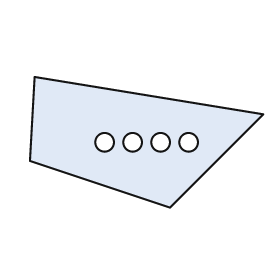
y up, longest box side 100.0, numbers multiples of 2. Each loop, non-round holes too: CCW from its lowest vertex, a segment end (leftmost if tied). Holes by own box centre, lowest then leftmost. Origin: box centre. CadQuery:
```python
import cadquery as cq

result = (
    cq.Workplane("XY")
    .moveTo(10.0, -28.0)
    .lineTo(50.0, 12.0)
    .lineTo(-48.0, 28.0)
    .lineTo(-50.0, -8.0)
    .close()
    .moveTo(-18.0, 0.0)
    .circle(4.0)
    .moveTo(-6.0, 0.0)
    .circle(4.0)
    .moveTo(6.0, 0.0)
    .circle(4.0)
    .moveTo(18.0, 0.0)
    .circle(4.0)
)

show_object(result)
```